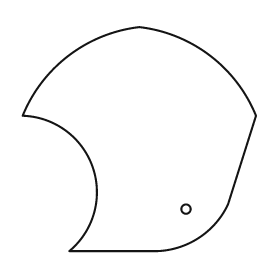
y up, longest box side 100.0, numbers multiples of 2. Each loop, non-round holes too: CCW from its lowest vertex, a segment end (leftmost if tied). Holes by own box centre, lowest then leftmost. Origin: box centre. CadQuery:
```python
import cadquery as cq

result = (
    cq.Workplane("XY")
    .moveTo(-30.0, -48.0)
    .lineTo(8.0, -48.0)
    .threePointArc((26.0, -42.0), (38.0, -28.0))
    .lineTo(50.0, 10.0)
    .threePointArc((30.0, 36.0), (0.0, 48.0))
    .threePointArc((-30.0, 36.0), (-50.0, 10.0))
    .threePointArc((-20.0, -12.0), (-30.0, -48.0))
    .close()
    .moveTo(20.0, -30.0)
    .circle(2.0)
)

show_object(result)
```